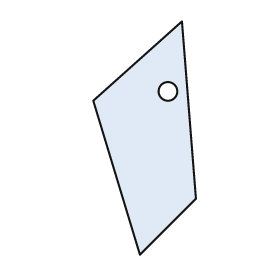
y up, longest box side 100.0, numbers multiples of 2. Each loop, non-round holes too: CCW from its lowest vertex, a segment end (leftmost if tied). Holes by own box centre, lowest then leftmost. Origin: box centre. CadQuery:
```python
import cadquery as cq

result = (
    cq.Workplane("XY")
    .moveTo(-2.0, -50.0)
    .lineTo(22.0, -26.0)
    .lineTo(16.0, 50.0)
    .lineTo(-22.0, 16.0)
    .close()
    .moveTo(10.0, 20.0)
    .circle(4.0)
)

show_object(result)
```